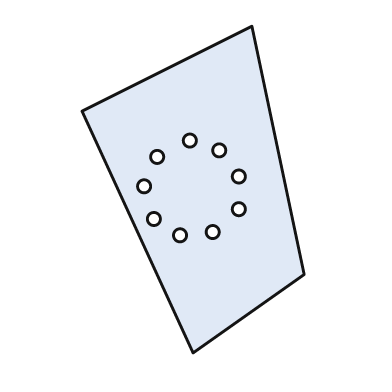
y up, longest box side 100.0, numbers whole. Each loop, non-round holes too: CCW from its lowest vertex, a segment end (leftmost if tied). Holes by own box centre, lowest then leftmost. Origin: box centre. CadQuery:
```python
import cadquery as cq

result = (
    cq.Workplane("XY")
    .moveTo(0.0, -50.0)
    .lineTo(34.0, -26.0)
    .lineTo(18.0, 50.0)
    .lineTo(-34.0, 24.0)
    .close()
    .moveTo(-4.0, -14.0)
    .circle(2.0)
    .moveTo(6.0, -13.0)
    .circle(2.0)
    .moveTo(-12.0, -9.0)
    .circle(2.0)
    .moveTo(14.0, -6.0)
    .circle(2.0)
    .moveTo(-15.0, 1.0)
    .circle(2.0)
    .moveTo(14.0, 4.0)
    .circle(2.0)
    .moveTo(-11.0, 10.0)
    .circle(2.0)
    .moveTo(8.0, 12.0)
    .circle(2.0)
    .moveTo(-1.0, 15.0)
    .circle(2.0)
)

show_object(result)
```